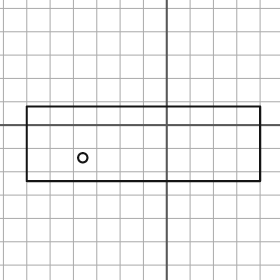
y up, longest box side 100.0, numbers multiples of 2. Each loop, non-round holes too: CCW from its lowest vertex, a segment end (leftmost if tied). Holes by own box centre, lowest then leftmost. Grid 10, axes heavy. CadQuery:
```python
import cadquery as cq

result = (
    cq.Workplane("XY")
    .moveTo(-60.0, -24.0)
    .lineTo(40.0, -24.0)
    .lineTo(40.0, 8.0)
    .lineTo(-60.0, 8.0)
    .close()
    .moveTo(-36.0, -14.0)
    .circle(2.0)
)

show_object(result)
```